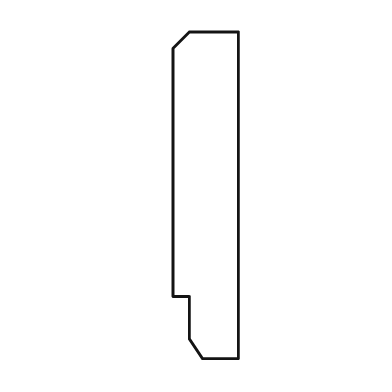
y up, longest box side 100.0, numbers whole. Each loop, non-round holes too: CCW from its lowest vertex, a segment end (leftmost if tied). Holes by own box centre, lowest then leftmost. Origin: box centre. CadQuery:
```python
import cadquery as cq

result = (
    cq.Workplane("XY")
    .moveTo(-1.0, -50.0)
    .lineTo(10.0, -50.0)
    .lineTo(10.0, 50.0)
    .lineTo(-5.0, 50.0)
    .lineTo(-10.0, 45.0)
    .lineTo(-10.0, -31.0)
    .lineTo(-5.0, -31.0)
    .lineTo(-5.0, -44.0)
    .close()
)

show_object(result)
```